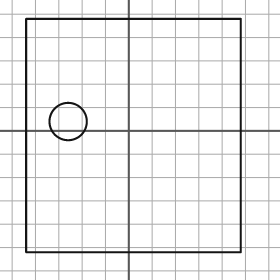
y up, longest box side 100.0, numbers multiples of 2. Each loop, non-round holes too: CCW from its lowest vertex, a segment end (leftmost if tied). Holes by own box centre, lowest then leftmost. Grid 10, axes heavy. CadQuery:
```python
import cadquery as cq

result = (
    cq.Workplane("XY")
    .moveTo(-44.0, -52.0)
    .lineTo(48.0, -52.0)
    .lineTo(48.0, 48.0)
    .lineTo(-44.0, 48.0)
    .close()
    .moveTo(-26.0, 4.0)
    .circle(8.0)
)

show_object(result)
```